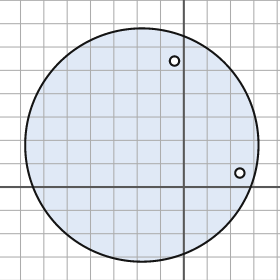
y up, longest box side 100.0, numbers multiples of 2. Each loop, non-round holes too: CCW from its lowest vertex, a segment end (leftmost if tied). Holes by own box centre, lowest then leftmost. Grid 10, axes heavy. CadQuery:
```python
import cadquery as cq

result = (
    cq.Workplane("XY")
    .moveTo(-18.0, 18.0)
    .circle(50.0)
    .moveTo(24.0, 6.0)
    .circle(2.0)
    .moveTo(-4.0, 54.0)
    .circle(2.0)
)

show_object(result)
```